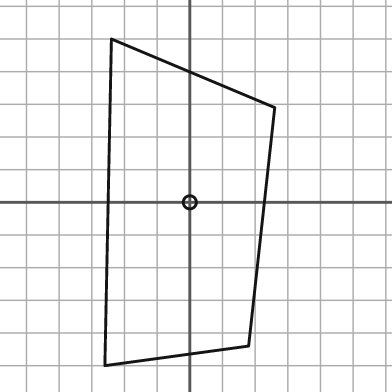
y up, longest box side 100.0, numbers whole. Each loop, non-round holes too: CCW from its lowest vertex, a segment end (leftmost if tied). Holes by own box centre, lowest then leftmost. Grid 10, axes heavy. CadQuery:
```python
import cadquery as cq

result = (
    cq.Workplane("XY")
    .moveTo(-26.0, -50.0)
    .lineTo(18.0, -44.0)
    .lineTo(26.0, 29.0)
    .lineTo(-24.0, 50.0)
    .close()
    .moveTo(0.0, 0.0)
    .circle(2.0)
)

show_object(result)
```